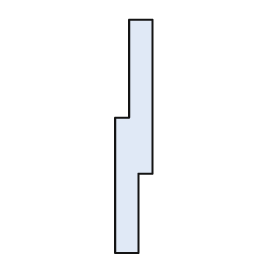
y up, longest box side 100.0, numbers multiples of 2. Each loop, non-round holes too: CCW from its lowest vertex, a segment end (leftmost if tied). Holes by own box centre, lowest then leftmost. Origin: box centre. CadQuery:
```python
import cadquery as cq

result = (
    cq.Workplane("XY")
    .moveTo(-8.0, -50.0)
    .lineTo(2.0, -50.0)
    .lineTo(2.0, -16.0)
    .lineTo(8.0, -16.0)
    .lineTo(8.0, 50.0)
    .lineTo(-2.0, 50.0)
    .lineTo(-2.0, 8.0)
    .lineTo(-8.0, 8.0)
    .close()
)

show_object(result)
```